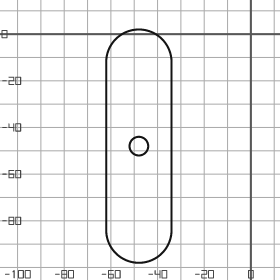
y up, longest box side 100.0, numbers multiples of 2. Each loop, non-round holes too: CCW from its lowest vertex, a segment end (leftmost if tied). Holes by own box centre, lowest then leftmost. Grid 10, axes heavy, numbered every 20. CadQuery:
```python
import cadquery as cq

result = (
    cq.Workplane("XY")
    .moveTo(-62.0, -84.0)
    .threePointArc((-48.0, -98.0), (-34.0, -84.0))
    .lineTo(-34.0, -12.0)
    .threePointArc((-48.0, 2.0), (-62.0, -12.0))
    .close()
    .moveTo(-48.0, -48.0)
    .circle(4.0)
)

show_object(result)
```